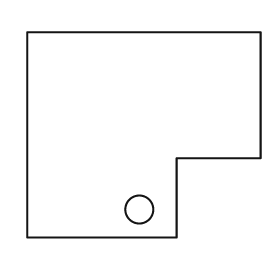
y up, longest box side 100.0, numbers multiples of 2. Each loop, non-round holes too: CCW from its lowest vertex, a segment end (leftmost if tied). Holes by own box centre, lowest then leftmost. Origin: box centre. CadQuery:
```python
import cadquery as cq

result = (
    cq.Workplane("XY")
    .moveTo(-50.0, -44.0)
    .lineTo(14.0, -44.0)
    .lineTo(14.0, -10.0)
    .lineTo(50.0, -10.0)
    .lineTo(50.0, 44.0)
    .lineTo(-50.0, 44.0)
    .close()
    .moveTo(-2.0, -32.0)
    .circle(6.0)
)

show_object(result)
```